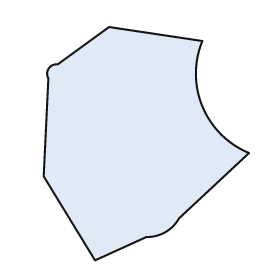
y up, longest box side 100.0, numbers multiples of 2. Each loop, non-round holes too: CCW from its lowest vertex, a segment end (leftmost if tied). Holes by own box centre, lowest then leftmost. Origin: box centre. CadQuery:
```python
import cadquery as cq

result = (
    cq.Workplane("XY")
    .moveTo(-22.0, -50.0)
    .lineTo(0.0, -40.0)
    .threePointArc((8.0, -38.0), (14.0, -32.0))
    .lineTo(44.0, -4.0)
    .threePointArc((24.0, 16.0), (24.0, 44.0))
    .lineTo(-16.0, 50.0)
    .lineTo(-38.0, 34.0)
    .threePointArc((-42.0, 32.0), (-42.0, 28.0))
    .lineTo(-44.0, -14.0)
    .close()
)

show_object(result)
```